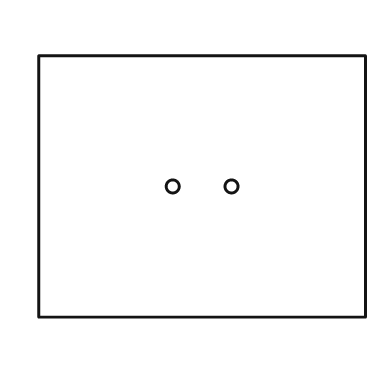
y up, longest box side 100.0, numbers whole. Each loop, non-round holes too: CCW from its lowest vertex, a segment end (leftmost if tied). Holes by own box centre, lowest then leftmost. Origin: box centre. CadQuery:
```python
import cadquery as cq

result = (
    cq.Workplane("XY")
    .moveTo(-50.0, -40.0)
    .lineTo(50.0, -40.0)
    .lineTo(50.0, 40.0)
    .lineTo(-50.0, 40.0)
    .close()
    .moveTo(-9.0, 0.0)
    .circle(2.0)
    .moveTo(9.0, 0.0)
    .circle(2.0)
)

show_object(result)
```